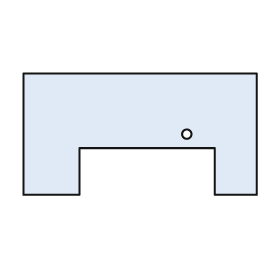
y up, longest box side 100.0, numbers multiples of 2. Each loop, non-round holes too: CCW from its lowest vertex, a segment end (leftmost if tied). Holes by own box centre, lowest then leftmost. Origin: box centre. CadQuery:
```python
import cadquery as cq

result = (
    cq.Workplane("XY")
    .moveTo(-50.0, -26.0)
    .lineTo(-26.0, -26.0)
    .lineTo(-26.0, -6.0)
    .lineTo(32.0, -6.0)
    .lineTo(32.0, -26.0)
    .lineTo(50.0, -26.0)
    .lineTo(50.0, 26.0)
    .lineTo(-50.0, 26.0)
    .close()
    .moveTo(20.0, 0.0)
    .circle(2.0)
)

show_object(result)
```